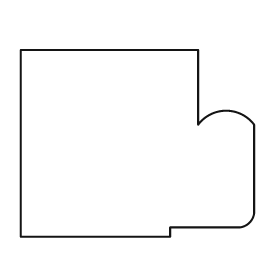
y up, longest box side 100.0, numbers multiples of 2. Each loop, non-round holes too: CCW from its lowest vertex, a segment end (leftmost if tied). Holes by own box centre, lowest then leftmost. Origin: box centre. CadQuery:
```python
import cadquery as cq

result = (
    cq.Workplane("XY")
    .moveTo(-50.0, -40.0)
    .lineTo(14.0, -40.0)
    .lineTo(14.0, -36.0)
    .lineTo(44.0, -36.0)
    .threePointArc((48.0, -34.0), (50.0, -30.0))
    .lineTo(50.0, 8.0)
    .threePointArc((38.0, 14.0), (26.0, 8.0))
    .lineTo(26.0, 40.0)
    .lineTo(-50.0, 40.0)
    .close()
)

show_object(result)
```